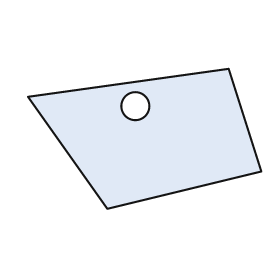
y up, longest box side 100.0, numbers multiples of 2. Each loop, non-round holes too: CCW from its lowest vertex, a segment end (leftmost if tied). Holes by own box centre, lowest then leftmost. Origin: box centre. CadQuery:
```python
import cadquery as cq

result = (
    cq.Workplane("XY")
    .moveTo(-16.0, -30.0)
    .lineTo(50.0, -14.0)
    .lineTo(36.0, 30.0)
    .lineTo(-50.0, 18.0)
    .close()
    .moveTo(-4.0, 14.0)
    .circle(6.0)
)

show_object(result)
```